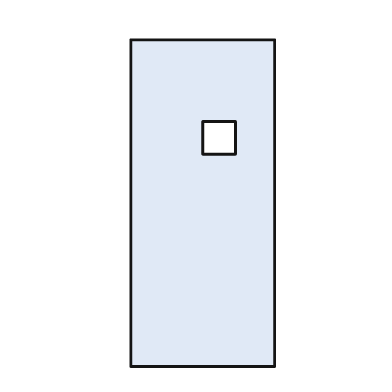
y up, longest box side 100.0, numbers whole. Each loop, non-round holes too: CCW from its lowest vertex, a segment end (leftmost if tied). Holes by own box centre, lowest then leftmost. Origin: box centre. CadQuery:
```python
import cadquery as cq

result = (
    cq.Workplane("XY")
    .moveTo(-22.0, -50.0)
    .lineTo(22.0, -50.0)
    .lineTo(22.0, 50.0)
    .lineTo(-22.0, 50.0)
    .close()
    .moveTo(0.0, 15.0)
    .lineTo(10.0, 15.0)
    .lineTo(10.0, 25.0)
    .lineTo(0.0, 25.0)
    .close()
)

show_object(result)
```